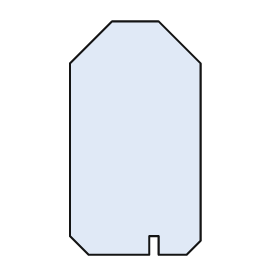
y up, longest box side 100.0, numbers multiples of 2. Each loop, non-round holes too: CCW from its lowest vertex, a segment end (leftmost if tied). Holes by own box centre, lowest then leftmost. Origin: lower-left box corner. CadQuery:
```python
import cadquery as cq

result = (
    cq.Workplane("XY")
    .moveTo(8.0, 0.0)
    .lineTo(34.0, 0.0)
    .lineTo(34.0, 8.0)
    .lineTo(38.0, 8.0)
    .lineTo(38.0, 0.0)
    .lineTo(50.0, 0.0)
    .lineTo(56.0, 6.0)
    .lineTo(56.0, 82.0)
    .lineTo(38.0, 100.0)
    .lineTo(18.0, 100.0)
    .lineTo(0.0, 82.0)
    .lineTo(0.0, 8.0)
    .close()
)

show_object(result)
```